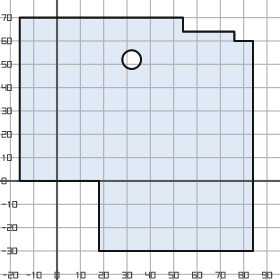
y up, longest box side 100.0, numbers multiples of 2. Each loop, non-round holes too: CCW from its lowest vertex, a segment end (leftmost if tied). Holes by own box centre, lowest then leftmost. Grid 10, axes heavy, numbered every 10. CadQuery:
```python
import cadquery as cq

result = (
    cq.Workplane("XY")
    .moveTo(18.0, -30.0)
    .lineTo(84.0, -30.0)
    .lineTo(84.0, 60.0)
    .lineTo(76.0, 60.0)
    .lineTo(76.0, 64.0)
    .lineTo(54.0, 64.0)
    .lineTo(54.0, 70.0)
    .lineTo(-16.0, 70.0)
    .lineTo(-16.0, 0.0)
    .lineTo(18.0, 0.0)
    .close()
    .moveTo(32.0, 52.0)
    .circle(4.0)
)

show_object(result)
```